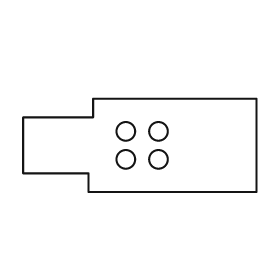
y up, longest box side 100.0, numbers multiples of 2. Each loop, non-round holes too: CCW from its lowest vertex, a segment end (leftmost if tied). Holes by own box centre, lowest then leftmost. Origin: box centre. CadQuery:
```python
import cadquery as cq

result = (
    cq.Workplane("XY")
    .moveTo(-22.0, -20.0)
    .lineTo(50.0, -20.0)
    .lineTo(50.0, 20.0)
    .lineTo(-20.0, 20.0)
    .lineTo(-20.0, 12.0)
    .lineTo(-50.0, 12.0)
    .lineTo(-50.0, -12.0)
    .lineTo(-22.0, -12.0)
    .close()
    .moveTo(-6.0, -6.0)
    .circle(4.0)
    .moveTo(8.0, -6.0)
    .circle(4.0)
    .moveTo(-6.0, 6.0)
    .circle(4.0)
    .moveTo(8.0, 6.0)
    .circle(4.0)
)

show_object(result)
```